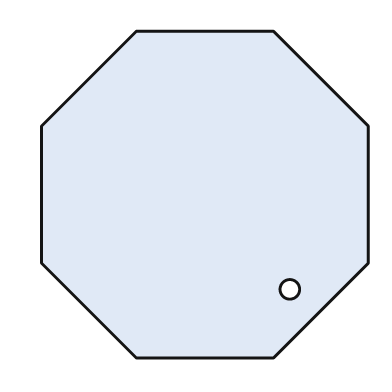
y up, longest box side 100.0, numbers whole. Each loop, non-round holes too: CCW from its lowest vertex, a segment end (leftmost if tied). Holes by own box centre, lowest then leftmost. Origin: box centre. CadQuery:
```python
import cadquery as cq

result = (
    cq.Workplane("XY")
    .moveTo(-21.0, -50.0)
    .lineTo(21.0, -50.0)
    .lineTo(50.0, -21.0)
    .lineTo(50.0, 21.0)
    .lineTo(21.0, 50.0)
    .lineTo(-21.0, 50.0)
    .lineTo(-50.0, 21.0)
    .lineTo(-50.0, -21.0)
    .close()
    .moveTo(26.0, -29.0)
    .circle(3.0)
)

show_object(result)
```